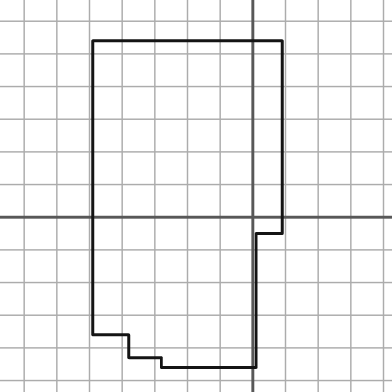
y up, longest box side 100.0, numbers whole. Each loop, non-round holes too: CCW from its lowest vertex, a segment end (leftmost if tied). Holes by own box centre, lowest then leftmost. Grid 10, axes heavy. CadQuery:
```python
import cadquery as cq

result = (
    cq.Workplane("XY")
    .moveTo(-28.0, -46.0)
    .lineTo(1.0, -46.0)
    .lineTo(1.0, -5.0)
    .lineTo(9.0, -5.0)
    .lineTo(9.0, 54.0)
    .lineTo(-49.0, 54.0)
    .lineTo(-49.0, -36.0)
    .lineTo(-38.0, -36.0)
    .lineTo(-38.0, -43.0)
    .lineTo(-28.0, -43.0)
    .close()
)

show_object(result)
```